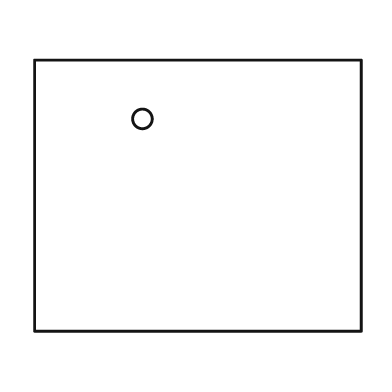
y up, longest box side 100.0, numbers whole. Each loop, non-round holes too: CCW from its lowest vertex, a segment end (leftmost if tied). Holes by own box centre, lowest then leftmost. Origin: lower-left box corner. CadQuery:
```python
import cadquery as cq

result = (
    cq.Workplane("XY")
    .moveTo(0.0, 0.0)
    .lineTo(100.0, 0.0)
    .lineTo(100.0, 83.0)
    .lineTo(0.0, 83.0)
    .close()
    .moveTo(33.0, 65.0)
    .circle(3.0)
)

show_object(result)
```